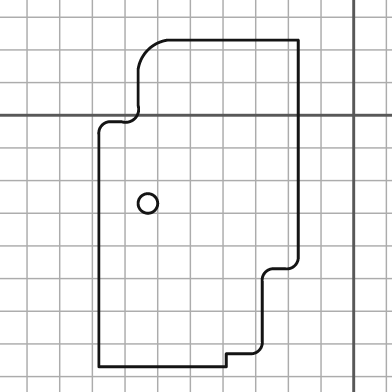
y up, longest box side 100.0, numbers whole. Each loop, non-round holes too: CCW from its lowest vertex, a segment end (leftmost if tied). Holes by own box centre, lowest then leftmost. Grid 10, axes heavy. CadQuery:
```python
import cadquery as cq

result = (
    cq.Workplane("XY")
    .moveTo(-78.0, -77.0)
    .lineTo(-39.0, -77.0)
    .lineTo(-39.0, -73.0)
    .lineTo(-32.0, -73.0)
    .threePointArc((-29.0, -72.0), (-28.0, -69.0))
    .lineTo(-28.0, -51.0)
    .threePointArc((-27.0, -48.0), (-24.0, -47.0))
    .lineTo(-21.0, -47.0)
    .threePointArc((-18.0, -46.0), (-17.0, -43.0))
    .lineTo(-17.0, 23.0)
    .lineTo(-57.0, 23.0)
    .threePointArc((-63.0, 20.0), (-66.0, 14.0))
    .lineTo(-66.0, 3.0)
    .threePointArc((-67.0, -1.0), (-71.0, -2.0))
    .lineTo(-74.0, -2.0)
    .threePointArc((-77.0, -3.0), (-78.0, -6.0))
    .close()
    .moveTo(-63.0, -27.0)
    .circle(3.0)
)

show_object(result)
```